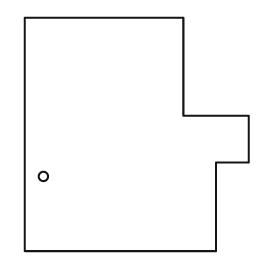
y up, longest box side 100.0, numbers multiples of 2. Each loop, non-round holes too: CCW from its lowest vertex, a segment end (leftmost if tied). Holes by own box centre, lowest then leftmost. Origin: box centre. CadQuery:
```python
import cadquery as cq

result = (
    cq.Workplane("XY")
    .moveTo(-48.0, -50.0)
    .lineTo(34.0, -50.0)
    .lineTo(34.0, -12.0)
    .lineTo(48.0, -12.0)
    .lineTo(48.0, 8.0)
    .lineTo(20.0, 8.0)
    .lineTo(20.0, 50.0)
    .lineTo(-48.0, 50.0)
    .close()
    .moveTo(-40.0, -18.0)
    .circle(2.0)
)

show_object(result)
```